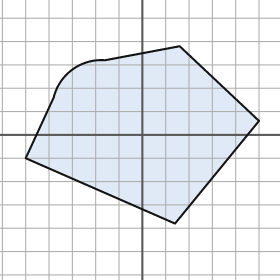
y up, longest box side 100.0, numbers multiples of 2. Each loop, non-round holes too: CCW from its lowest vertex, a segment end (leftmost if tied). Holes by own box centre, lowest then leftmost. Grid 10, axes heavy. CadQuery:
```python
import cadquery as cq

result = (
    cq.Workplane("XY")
    .moveTo(14.0, -38.0)
    .lineTo(50.0, 6.0)
    .lineTo(16.0, 38.0)
    .lineTo(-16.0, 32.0)
    .threePointArc((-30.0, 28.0), (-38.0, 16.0))
    .lineTo(-50.0, -10.0)
    .close()
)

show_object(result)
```